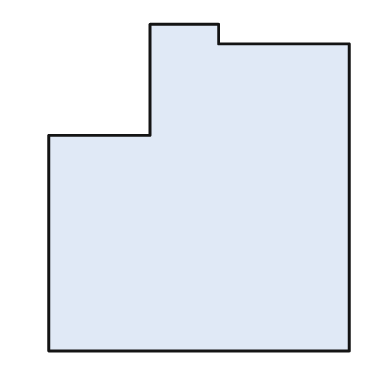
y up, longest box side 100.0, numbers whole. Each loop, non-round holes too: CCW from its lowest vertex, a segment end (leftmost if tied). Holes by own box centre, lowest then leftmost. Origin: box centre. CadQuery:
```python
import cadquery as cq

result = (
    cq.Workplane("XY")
    .moveTo(-46.0, -50.0)
    .lineTo(46.0, -50.0)
    .lineTo(46.0, 44.0)
    .lineTo(6.0, 44.0)
    .lineTo(6.0, 50.0)
    .lineTo(-15.0, 50.0)
    .lineTo(-15.0, 16.0)
    .lineTo(-46.0, 16.0)
    .close()
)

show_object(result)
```